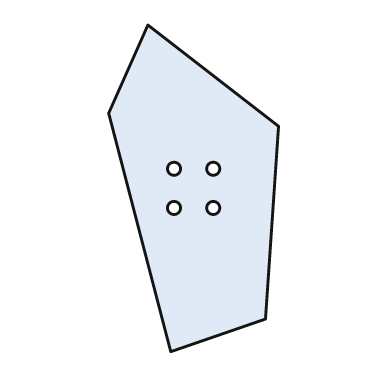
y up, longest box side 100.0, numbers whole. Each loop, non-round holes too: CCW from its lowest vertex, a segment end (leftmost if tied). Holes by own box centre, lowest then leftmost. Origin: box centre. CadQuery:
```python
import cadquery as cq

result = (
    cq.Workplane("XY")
    .moveTo(-7.0, -50.0)
    .lineTo(22.0, -40.0)
    .lineTo(26.0, 19.0)
    .lineTo(-14.0, 50.0)
    .lineTo(-26.0, 23.0)
    .close()
    .moveTo(-6.0, -6.0)
    .circle(2.0)
    .moveTo(6.0, -6.0)
    .circle(2.0)
    .moveTo(-6.0, 6.0)
    .circle(2.0)
    .moveTo(6.0, 6.0)
    .circle(2.0)
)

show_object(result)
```